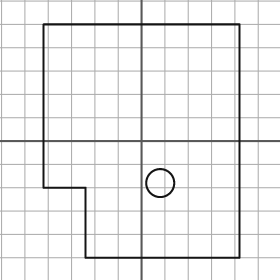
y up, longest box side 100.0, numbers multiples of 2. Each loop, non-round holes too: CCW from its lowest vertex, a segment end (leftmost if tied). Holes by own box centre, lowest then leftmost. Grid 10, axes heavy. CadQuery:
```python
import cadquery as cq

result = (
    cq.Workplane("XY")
    .moveTo(-24.0, -50.0)
    .lineTo(42.0, -50.0)
    .lineTo(42.0, 50.0)
    .lineTo(-42.0, 50.0)
    .lineTo(-42.0, -20.0)
    .lineTo(-24.0, -20.0)
    .close()
    .moveTo(8.0, -18.0)
    .circle(6.0)
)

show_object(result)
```